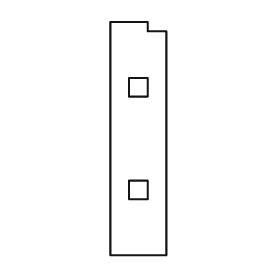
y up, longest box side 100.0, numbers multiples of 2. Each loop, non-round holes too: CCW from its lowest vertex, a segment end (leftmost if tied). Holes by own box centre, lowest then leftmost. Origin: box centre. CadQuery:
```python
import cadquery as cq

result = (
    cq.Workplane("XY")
    .moveTo(-12.0, -50.0)
    .lineTo(12.0, -50.0)
    .lineTo(12.0, 46.0)
    .lineTo(4.0, 46.0)
    .lineTo(4.0, 50.0)
    .lineTo(-12.0, 50.0)
    .close()
    .moveTo(-4.0, -26.0)
    .lineTo(4.0, -26.0)
    .lineTo(4.0, -18.0)
    .lineTo(-4.0, -18.0)
    .close()
    .moveTo(-4.0, 18.0)
    .lineTo(4.0, 18.0)
    .lineTo(4.0, 26.0)
    .lineTo(-4.0, 26.0)
    .close()
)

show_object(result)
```